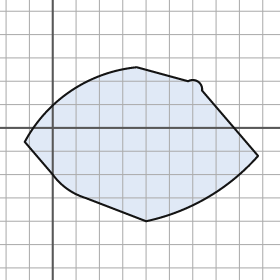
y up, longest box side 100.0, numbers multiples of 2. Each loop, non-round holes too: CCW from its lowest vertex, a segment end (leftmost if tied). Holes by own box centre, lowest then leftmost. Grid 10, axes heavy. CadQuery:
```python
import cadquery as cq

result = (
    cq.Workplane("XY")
    .moveTo(40.0, -40.0)
    .threePointArc((66.0, -30.0), (88.0, -12.0))
    .lineTo(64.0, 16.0)
    .threePointArc((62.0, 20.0), (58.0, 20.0))
    .lineTo(36.0, 26.0)
    .threePointArc((8.0, 16.0), (-12.0, -6.0))
    .lineTo(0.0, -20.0)
    .threePointArc((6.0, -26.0), (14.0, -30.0))
    .close()
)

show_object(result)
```